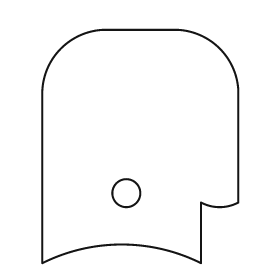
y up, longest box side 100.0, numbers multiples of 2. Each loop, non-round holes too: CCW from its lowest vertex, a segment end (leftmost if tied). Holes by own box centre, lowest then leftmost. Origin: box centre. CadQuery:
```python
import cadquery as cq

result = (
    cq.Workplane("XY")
    .moveTo(-42.0, -50.0)
    .threePointArc((-8.0, -42.0), (26.0, -50.0))
    .lineTo(26.0, -24.0)
    .threePointArc((34.0, -26.0), (42.0, -24.0))
    .lineTo(42.0, 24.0)
    .threePointArc((34.0, 42.0), (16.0, 50.0))
    .lineTo(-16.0, 50.0)
    .threePointArc((-34.0, 42.0), (-42.0, 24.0))
    .close()
    .moveTo(-6.0, -20.0)
    .circle(6.0)
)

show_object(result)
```